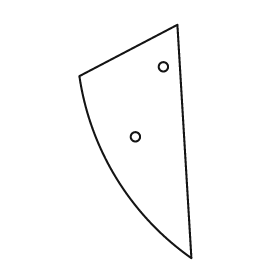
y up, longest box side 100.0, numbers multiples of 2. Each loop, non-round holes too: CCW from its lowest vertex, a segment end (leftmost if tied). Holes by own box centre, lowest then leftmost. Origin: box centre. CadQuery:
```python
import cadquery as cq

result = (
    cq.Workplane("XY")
    .moveTo(24.0, -50.0)
    .lineTo(18.0, 50.0)
    .lineTo(-24.0, 28.0)
    .threePointArc((-8.0, -16.0), (24.0, -50.0))
    .close()
    .moveTo(0.0, 2.0)
    .circle(2.0)
    .moveTo(12.0, 32.0)
    .circle(2.0)
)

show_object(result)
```